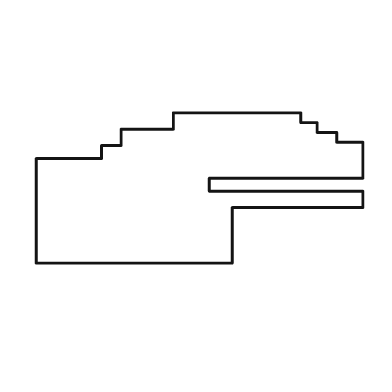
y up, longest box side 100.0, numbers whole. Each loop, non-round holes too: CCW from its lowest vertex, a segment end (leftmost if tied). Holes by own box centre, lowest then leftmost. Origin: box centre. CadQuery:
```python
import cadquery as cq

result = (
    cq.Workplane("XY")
    .moveTo(-50.0, -23.0)
    .lineTo(10.0, -23.0)
    .lineTo(10.0, -6.0)
    .lineTo(50.0, -6.0)
    .lineTo(50.0, -1.0)
    .lineTo(3.0, -1.0)
    .lineTo(3.0, 3.0)
    .lineTo(50.0, 3.0)
    .lineTo(50.0, 14.0)
    .lineTo(42.0, 14.0)
    .lineTo(42.0, 17.0)
    .lineTo(36.0, 17.0)
    .lineTo(36.0, 20.0)
    .lineTo(31.0, 20.0)
    .lineTo(31.0, 23.0)
    .lineTo(-8.0, 23.0)
    .lineTo(-8.0, 18.0)
    .lineTo(-24.0, 18.0)
    .lineTo(-24.0, 13.0)
    .lineTo(-30.0, 13.0)
    .lineTo(-30.0, 9.0)
    .lineTo(-50.0, 9.0)
    .close()
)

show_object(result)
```